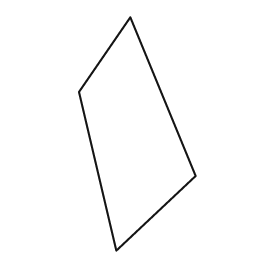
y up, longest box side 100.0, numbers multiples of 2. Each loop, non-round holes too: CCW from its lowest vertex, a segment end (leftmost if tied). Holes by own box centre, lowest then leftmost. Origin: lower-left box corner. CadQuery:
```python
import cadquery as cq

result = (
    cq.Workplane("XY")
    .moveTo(16.0, 0.0)
    .lineTo(50.0, 32.0)
    .lineTo(22.0, 100.0)
    .lineTo(0.0, 68.0)
    .close()
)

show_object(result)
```